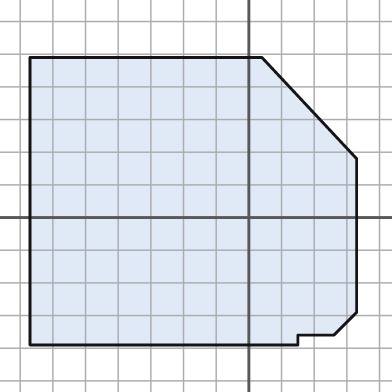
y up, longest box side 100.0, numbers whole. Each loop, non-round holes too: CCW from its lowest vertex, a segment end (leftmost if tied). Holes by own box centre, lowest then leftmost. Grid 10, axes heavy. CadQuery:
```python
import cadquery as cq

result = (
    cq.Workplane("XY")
    .moveTo(-67.0, -39.0)
    .lineTo(15.0, -39.0)
    .lineTo(15.0, -36.0)
    .lineTo(26.0, -36.0)
    .lineTo(33.0, -29.0)
    .lineTo(33.0, 18.0)
    .lineTo(4.0, 49.0)
    .lineTo(-67.0, 49.0)
    .close()
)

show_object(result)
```